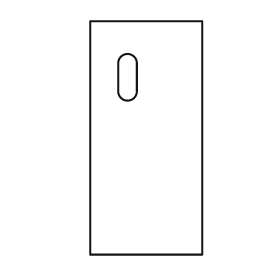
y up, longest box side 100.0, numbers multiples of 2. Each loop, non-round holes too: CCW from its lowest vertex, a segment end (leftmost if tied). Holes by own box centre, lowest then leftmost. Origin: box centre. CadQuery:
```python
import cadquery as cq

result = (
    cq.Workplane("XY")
    .moveTo(-24.0, -50.0)
    .lineTo(24.0, -50.0)
    .lineTo(24.0, 50.0)
    .lineTo(-24.0, 50.0)
    .close()
    .moveTo(-12.0, 20.0)
    .threePointArc((-8.0, 16.0), (-4.0, 20.0))
    .lineTo(-4.0, 32.0)
    .threePointArc((-8.0, 36.0), (-12.0, 32.0))
    .close()
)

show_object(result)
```